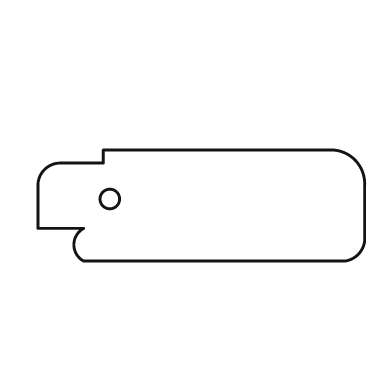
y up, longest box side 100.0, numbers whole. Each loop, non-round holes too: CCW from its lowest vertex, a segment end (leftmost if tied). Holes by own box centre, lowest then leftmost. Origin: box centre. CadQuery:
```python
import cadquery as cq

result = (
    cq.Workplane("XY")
    .moveTo(-36.0, -17.0)
    .lineTo(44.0, -17.0)
    .threePointArc((48.0, -15.0), (50.0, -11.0))
    .lineTo(50.0, 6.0)
    .threePointArc((47.0, 14.0), (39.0, 17.0))
    .lineTo(-30.0, 17.0)
    .lineTo(-30.0, 13.0)
    .lineTo(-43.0, 13.0)
    .threePointArc((-48.0, 11.0), (-50.0, 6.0))
    .lineTo(-50.0, -7.0)
    .lineTo(-36.0, -7.0)
    .threePointArc((-39.0, -12.0), (-36.0, -17.0))
    .close()
    .moveTo(-28.0, 2.0)
    .circle(3.0)
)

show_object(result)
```